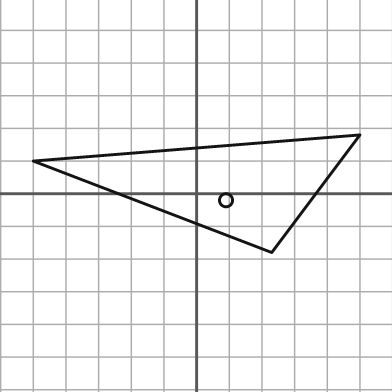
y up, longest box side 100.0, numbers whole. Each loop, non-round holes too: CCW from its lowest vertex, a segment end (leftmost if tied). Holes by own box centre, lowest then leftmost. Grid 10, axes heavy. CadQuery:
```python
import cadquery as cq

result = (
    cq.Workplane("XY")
    .moveTo(23.0, -18.0)
    .lineTo(50.0, 18.0)
    .lineTo(-50.0, 10.0)
    .close()
    .moveTo(9.0, -2.0)
    .circle(2.0)
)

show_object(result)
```